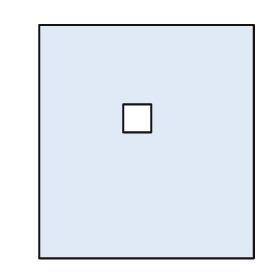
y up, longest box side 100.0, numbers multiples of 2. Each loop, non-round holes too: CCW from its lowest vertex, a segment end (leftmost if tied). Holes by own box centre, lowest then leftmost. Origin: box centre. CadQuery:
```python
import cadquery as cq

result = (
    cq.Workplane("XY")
    .moveTo(-46.0, -50.0)
    .lineTo(46.0, -50.0)
    .lineTo(46.0, 50.0)
    .lineTo(-46.0, 50.0)
    .close()
    .moveTo(-10.0, 4.0)
    .lineTo(2.0, 4.0)
    .lineTo(2.0, 16.0)
    .lineTo(-10.0, 16.0)
    .close()
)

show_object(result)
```